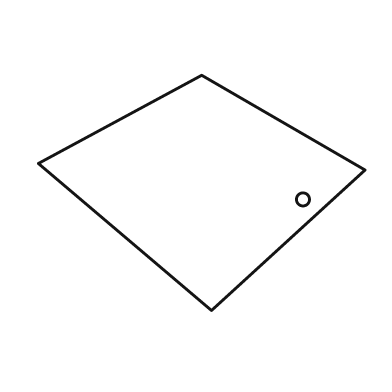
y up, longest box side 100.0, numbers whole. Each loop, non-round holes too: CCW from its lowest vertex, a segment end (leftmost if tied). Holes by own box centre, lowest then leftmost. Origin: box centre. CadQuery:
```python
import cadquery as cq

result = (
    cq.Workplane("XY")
    .moveTo(3.0, -36.0)
    .lineTo(50.0, 7.0)
    .lineTo(0.0, 36.0)
    .lineTo(-50.0, 9.0)
    .close()
    .moveTo(31.0, -2.0)
    .circle(2.0)
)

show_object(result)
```